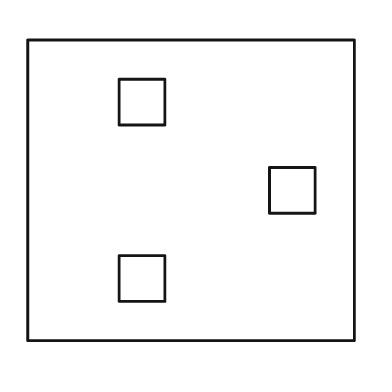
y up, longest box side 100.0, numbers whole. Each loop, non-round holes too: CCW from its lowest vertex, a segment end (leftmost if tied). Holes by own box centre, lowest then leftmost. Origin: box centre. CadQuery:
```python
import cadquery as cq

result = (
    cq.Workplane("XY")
    .moveTo(-50.0, -46.0)
    .lineTo(50.0, -46.0)
    .lineTo(50.0, 46.0)
    .lineTo(-50.0, 46.0)
    .close()
    .moveTo(-22.0, -34.0)
    .lineTo(-8.0, -34.0)
    .lineTo(-8.0, -20.0)
    .lineTo(-22.0, -20.0)
    .close()
    .moveTo(24.0, -7.0)
    .lineTo(38.0, -7.0)
    .lineTo(38.0, 7.0)
    .lineTo(24.0, 7.0)
    .close()
    .moveTo(-22.0, 20.0)
    .lineTo(-8.0, 20.0)
    .lineTo(-8.0, 34.0)
    .lineTo(-22.0, 34.0)
    .close()
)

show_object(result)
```